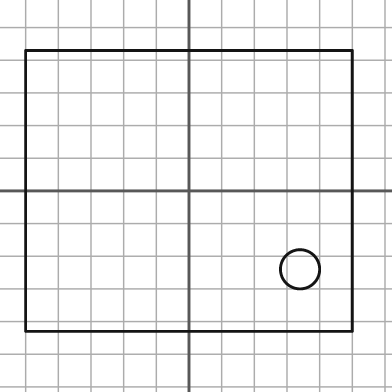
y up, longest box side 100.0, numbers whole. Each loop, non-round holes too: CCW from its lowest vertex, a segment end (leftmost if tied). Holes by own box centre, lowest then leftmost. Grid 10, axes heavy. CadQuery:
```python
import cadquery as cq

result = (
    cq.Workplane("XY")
    .moveTo(-50.0, -43.0)
    .lineTo(50.0, -43.0)
    .lineTo(50.0, 43.0)
    .lineTo(-50.0, 43.0)
    .close()
    .moveTo(34.0, -24.0)
    .circle(6.0)
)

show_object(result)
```